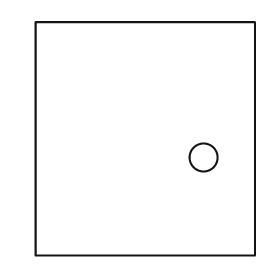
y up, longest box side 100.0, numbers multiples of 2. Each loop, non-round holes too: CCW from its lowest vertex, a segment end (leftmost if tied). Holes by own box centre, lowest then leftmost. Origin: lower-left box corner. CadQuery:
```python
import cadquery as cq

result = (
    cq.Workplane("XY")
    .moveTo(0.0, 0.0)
    .lineTo(94.0, 0.0)
    .lineTo(94.0, 100.0)
    .lineTo(0.0, 100.0)
    .close()
    .moveTo(72.0, 42.0)
    .circle(6.0)
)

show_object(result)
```